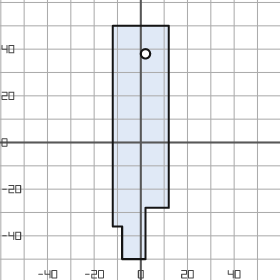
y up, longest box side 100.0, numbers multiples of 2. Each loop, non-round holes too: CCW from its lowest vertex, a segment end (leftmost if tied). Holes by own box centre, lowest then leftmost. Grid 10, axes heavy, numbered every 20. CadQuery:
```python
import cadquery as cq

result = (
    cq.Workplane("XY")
    .moveTo(-8.0, -50.0)
    .lineTo(2.0, -50.0)
    .lineTo(2.0, -28.0)
    .lineTo(12.0, -28.0)
    .lineTo(12.0, 50.0)
    .lineTo(-12.0, 50.0)
    .lineTo(-12.0, -36.0)
    .lineTo(-8.0, -36.0)
    .close()
    .moveTo(2.0, 38.0)
    .circle(2.0)
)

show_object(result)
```